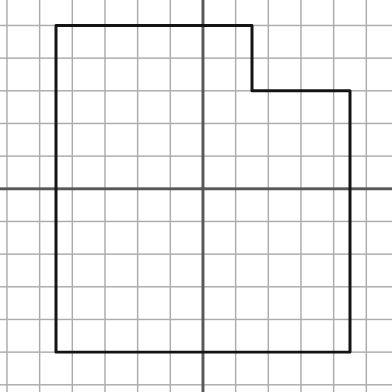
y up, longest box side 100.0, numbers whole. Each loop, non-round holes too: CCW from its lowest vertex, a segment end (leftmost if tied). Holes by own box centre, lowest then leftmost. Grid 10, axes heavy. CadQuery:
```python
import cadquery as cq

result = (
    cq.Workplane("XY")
    .moveTo(-45.0, -50.0)
    .lineTo(45.0, -50.0)
    .lineTo(45.0, 30.0)
    .lineTo(15.0, 30.0)
    .lineTo(15.0, 50.0)
    .lineTo(-45.0, 50.0)
    .close()
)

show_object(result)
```